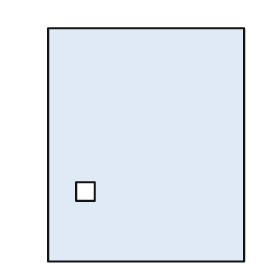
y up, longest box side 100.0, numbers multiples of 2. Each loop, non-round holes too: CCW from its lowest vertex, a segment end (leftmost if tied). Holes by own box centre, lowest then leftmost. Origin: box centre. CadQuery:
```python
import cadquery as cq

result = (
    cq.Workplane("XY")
    .moveTo(-42.0, -50.0)
    .lineTo(42.0, -50.0)
    .lineTo(42.0, 50.0)
    .lineTo(-42.0, 50.0)
    .close()
    .moveTo(-30.0, -24.0)
    .lineTo(-22.0, -24.0)
    .lineTo(-22.0, -16.0)
    .lineTo(-30.0, -16.0)
    .close()
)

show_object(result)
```